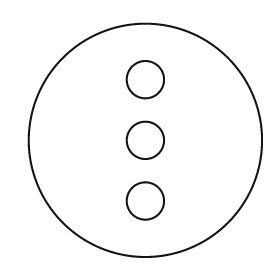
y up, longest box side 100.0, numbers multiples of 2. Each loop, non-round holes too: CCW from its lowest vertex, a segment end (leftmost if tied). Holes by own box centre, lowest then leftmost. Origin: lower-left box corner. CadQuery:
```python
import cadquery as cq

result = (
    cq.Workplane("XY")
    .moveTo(50.0, 50.0)
    .circle(50.0)
    .moveTo(50.0, 24.0)
    .circle(8.0)
    .moveTo(50.0, 50.0)
    .circle(8.0)
    .moveTo(50.0, 76.0)
    .circle(8.0)
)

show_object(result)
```